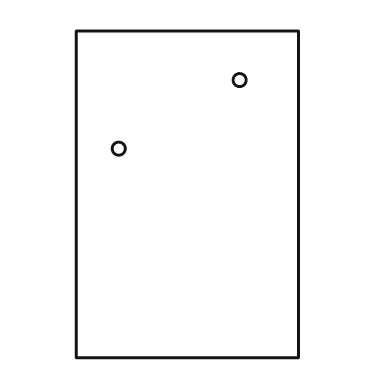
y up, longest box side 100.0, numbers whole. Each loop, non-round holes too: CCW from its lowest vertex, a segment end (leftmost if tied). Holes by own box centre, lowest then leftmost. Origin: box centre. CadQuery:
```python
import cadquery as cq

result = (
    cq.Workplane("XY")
    .moveTo(-34.0, -50.0)
    .lineTo(34.0, -50.0)
    .lineTo(34.0, 50.0)
    .lineTo(-34.0, 50.0)
    .close()
    .moveTo(-21.0, 14.0)
    .circle(2.0)
    .moveTo(16.0, 35.0)
    .circle(2.0)
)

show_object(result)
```